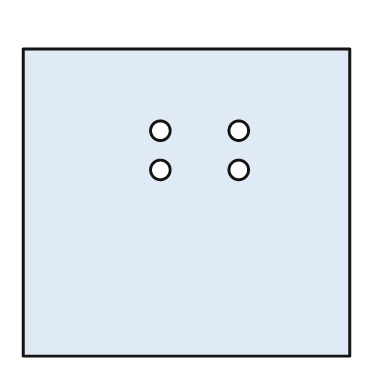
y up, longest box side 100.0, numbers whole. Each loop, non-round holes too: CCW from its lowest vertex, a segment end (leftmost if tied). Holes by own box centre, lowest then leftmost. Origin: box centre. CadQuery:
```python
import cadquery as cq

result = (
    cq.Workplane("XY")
    .moveTo(-50.0, -47.0)
    .lineTo(50.0, -47.0)
    .lineTo(50.0, 47.0)
    .lineTo(-50.0, 47.0)
    .close()
    .moveTo(-8.0, 10.0)
    .circle(3.0)
    .moveTo(16.0, 10.0)
    .circle(3.0)
    .moveTo(-8.0, 22.0)
    .circle(3.0)
    .moveTo(16.0, 22.0)
    .circle(3.0)
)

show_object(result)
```